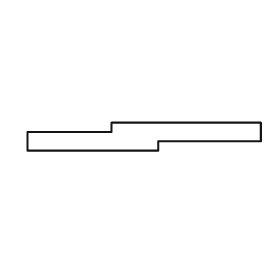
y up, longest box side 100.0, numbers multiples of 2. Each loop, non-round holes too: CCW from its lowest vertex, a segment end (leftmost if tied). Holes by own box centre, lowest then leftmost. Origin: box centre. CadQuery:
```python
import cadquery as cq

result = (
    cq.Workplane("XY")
    .moveTo(-50.0, -6.0)
    .lineTo(6.0, -6.0)
    .lineTo(6.0, -2.0)
    .lineTo(50.0, -2.0)
    .lineTo(50.0, 6.0)
    .lineTo(-14.0, 6.0)
    .lineTo(-14.0, 2.0)
    .lineTo(-50.0, 2.0)
    .close()
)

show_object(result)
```